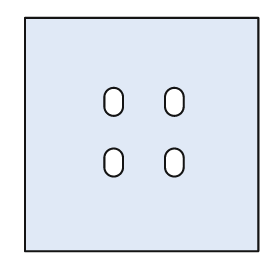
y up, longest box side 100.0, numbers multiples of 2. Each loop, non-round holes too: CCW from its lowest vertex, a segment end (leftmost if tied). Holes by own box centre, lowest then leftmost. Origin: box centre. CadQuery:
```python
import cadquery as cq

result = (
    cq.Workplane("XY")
    .moveTo(-50.0, -50.0)
    .lineTo(50.0, -50.0)
    .lineTo(50.0, 50.0)
    .lineTo(-50.0, 50.0)
    .close()
    .moveTo(-16.0, -14.0)
    .threePointArc((-12.0, -18.0), (-8.0, -14.0))
    .lineTo(-8.0, -10.0)
    .threePointArc((-12.0, -6.0), (-16.0, -10.0))
    .close()
    .moveTo(10.0, -14.0)
    .threePointArc((14.0, -18.0), (18.0, -14.0))
    .lineTo(18.0, -10.0)
    .threePointArc((14.0, -6.0), (10.0, -10.0))
    .close()
    .moveTo(-16.0, 12.0)
    .threePointArc((-12.0, 8.0), (-8.0, 12.0))
    .lineTo(-8.0, 16.0)
    .threePointArc((-12.0, 20.0), (-16.0, 16.0))
    .close()
    .moveTo(10.0, 12.0)
    .threePointArc((14.0, 8.0), (18.0, 12.0))
    .lineTo(18.0, 16.0)
    .threePointArc((14.0, 20.0), (10.0, 16.0))
    .close()
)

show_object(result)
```